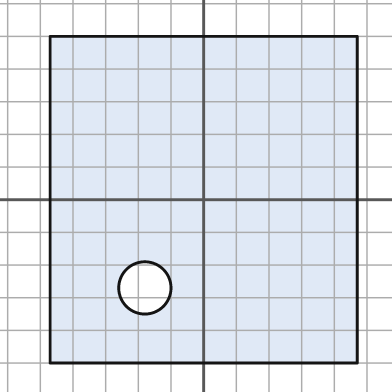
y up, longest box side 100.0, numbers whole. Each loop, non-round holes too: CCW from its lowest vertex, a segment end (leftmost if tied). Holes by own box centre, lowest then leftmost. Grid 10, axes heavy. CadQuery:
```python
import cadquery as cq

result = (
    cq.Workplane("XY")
    .moveTo(-47.0, -50.0)
    .lineTo(47.0, -50.0)
    .lineTo(47.0, 50.0)
    .lineTo(-47.0, 50.0)
    .close()
    .moveTo(-18.0, -27.0)
    .circle(8.0)
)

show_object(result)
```